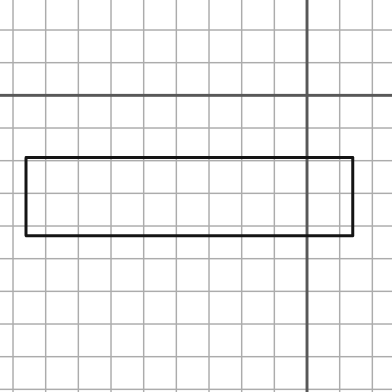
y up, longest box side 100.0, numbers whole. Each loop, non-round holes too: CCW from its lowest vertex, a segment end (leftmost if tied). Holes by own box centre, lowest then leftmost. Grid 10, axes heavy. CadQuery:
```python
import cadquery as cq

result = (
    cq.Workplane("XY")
    .moveTo(-86.0, -43.0)
    .lineTo(14.0, -43.0)
    .lineTo(14.0, -19.0)
    .lineTo(-86.0, -19.0)
    .close()
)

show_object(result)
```